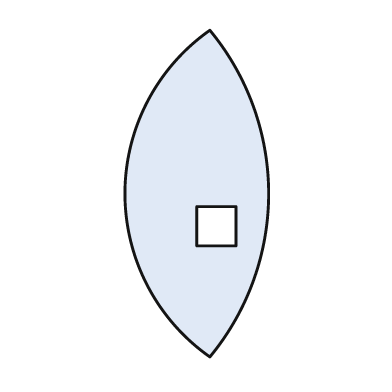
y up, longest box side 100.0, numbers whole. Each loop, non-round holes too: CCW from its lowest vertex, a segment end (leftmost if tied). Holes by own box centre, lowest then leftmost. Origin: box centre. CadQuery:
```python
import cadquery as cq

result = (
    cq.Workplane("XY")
    .moveTo(4.0, -50.0)
    .threePointArc((22.0, 0.0), (4.0, 50.0))
    .threePointArc((-22.0, 0.0), (4.0, -50.0))
    .close()
    .moveTo(0.0, -16.0)
    .lineTo(12.0, -16.0)
    .lineTo(12.0, -4.0)
    .lineTo(0.0, -4.0)
    .close()
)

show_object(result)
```